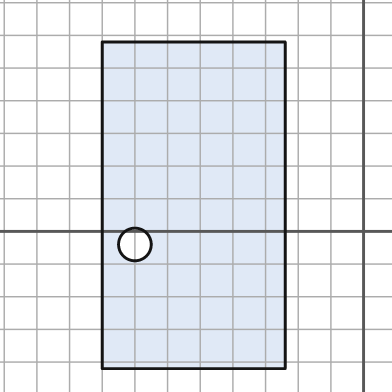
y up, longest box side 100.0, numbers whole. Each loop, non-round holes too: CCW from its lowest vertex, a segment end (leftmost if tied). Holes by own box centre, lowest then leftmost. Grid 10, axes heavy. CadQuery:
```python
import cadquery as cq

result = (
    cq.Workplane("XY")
    .moveTo(-80.0, -42.0)
    .lineTo(-24.0, -42.0)
    .lineTo(-24.0, 58.0)
    .lineTo(-80.0, 58.0)
    .close()
    .moveTo(-70.0, -4.0)
    .circle(5.0)
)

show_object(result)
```